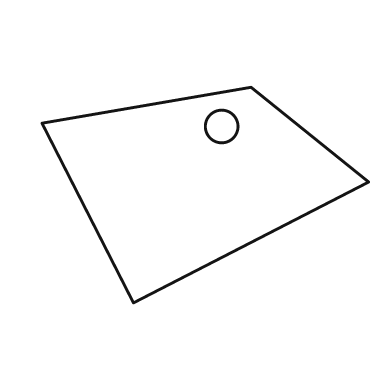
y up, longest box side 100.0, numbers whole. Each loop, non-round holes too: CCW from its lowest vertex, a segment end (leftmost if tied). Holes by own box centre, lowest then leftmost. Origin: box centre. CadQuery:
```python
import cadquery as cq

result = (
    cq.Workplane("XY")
    .moveTo(-22.0, -33.0)
    .lineTo(50.0, 4.0)
    .lineTo(14.0, 33.0)
    .lineTo(-50.0, 22.0)
    .close()
    .moveTo(5.0, 21.0)
    .circle(5.0)
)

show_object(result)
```